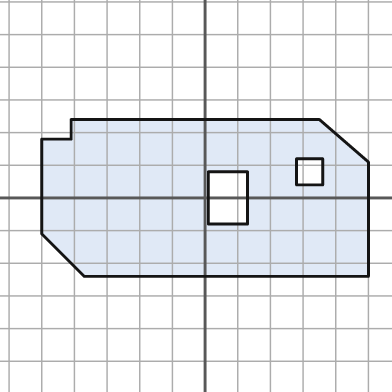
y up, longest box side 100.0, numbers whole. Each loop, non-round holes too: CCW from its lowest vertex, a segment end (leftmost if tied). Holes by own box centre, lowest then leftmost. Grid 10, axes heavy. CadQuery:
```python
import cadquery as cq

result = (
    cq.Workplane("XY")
    .moveTo(-37.0, -24.0)
    .lineTo(50.0, -24.0)
    .lineTo(50.0, 11.0)
    .lineTo(35.0, 24.0)
    .lineTo(-41.0, 24.0)
    .lineTo(-41.0, 18.0)
    .lineTo(-50.0, 18.0)
    .lineTo(-50.0, -11.0)
    .close()
    .moveTo(1.0, -8.0)
    .lineTo(13.0, -8.0)
    .lineTo(13.0, 8.0)
    .lineTo(1.0, 8.0)
    .close()
    .moveTo(28.0, 4.0)
    .lineTo(36.0, 4.0)
    .lineTo(36.0, 12.0)
    .lineTo(28.0, 12.0)
    .close()
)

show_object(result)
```